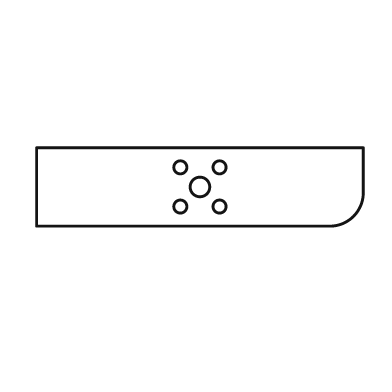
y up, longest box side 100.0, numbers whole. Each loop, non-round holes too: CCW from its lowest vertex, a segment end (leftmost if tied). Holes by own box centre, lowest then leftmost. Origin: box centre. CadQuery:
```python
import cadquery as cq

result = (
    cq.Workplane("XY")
    .moveTo(-50.0, -12.0)
    .lineTo(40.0, -12.0)
    .threePointArc((47.0, -9.0), (50.0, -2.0))
    .lineTo(50.0, 12.0)
    .lineTo(-50.0, 12.0)
    .close()
    .moveTo(-6.0, -6.0)
    .circle(2.0)
    .moveTo(6.0, -6.0)
    .circle(2.0)
    .moveTo(0.0, 0.0)
    .circle(3.0)
    .moveTo(-6.0, 6.0)
    .circle(2.0)
    .moveTo(6.0, 6.0)
    .circle(2.0)
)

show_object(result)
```